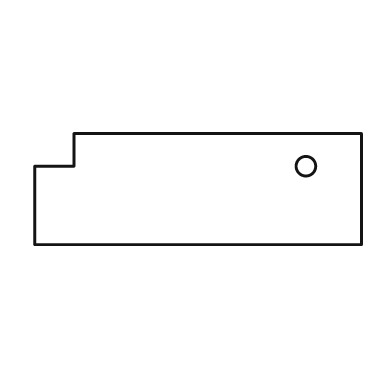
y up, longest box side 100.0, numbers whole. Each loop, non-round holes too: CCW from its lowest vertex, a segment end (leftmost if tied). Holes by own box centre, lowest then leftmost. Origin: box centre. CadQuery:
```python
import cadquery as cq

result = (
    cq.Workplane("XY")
    .moveTo(-50.0, -17.0)
    .lineTo(50.0, -17.0)
    .lineTo(50.0, 17.0)
    .lineTo(-38.0, 17.0)
    .lineTo(-38.0, 7.0)
    .lineTo(-50.0, 7.0)
    .close()
    .moveTo(33.0, 7.0)
    .circle(3.0)
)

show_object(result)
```